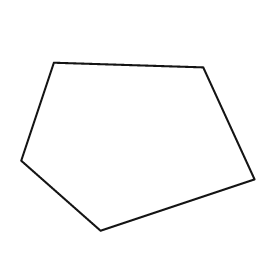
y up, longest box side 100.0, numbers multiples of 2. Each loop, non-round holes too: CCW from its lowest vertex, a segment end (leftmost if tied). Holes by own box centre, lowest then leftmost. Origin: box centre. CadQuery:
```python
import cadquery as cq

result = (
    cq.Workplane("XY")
    .moveTo(-16.0, -36.0)
    .lineTo(50.0, -14.0)
    .lineTo(28.0, 34.0)
    .lineTo(-36.0, 36.0)
    .lineTo(-50.0, -6.0)
    .close()
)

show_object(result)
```